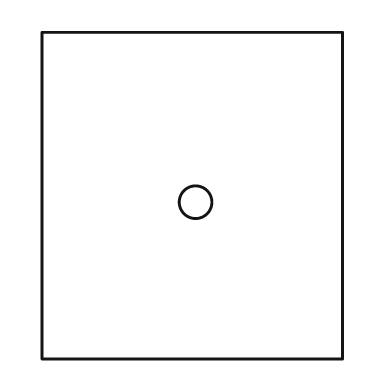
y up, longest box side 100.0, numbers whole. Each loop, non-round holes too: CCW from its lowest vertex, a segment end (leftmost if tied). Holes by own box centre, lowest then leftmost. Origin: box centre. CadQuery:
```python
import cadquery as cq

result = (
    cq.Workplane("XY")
    .moveTo(-46.0, -50.0)
    .lineTo(46.0, -50.0)
    .lineTo(46.0, 50.0)
    .lineTo(-46.0, 50.0)
    .close()
    .moveTo(1.0, -2.0)
    .circle(5.0)
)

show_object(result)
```